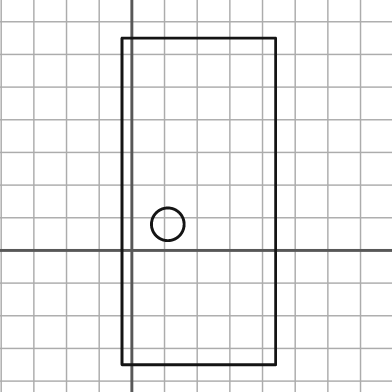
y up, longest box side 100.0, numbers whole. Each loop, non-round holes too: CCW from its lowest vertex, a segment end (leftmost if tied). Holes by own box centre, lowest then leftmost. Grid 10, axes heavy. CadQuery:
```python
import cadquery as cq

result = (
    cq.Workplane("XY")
    .moveTo(-3.0, -35.0)
    .lineTo(44.0, -35.0)
    .lineTo(44.0, 65.0)
    .lineTo(-3.0, 65.0)
    .close()
    .moveTo(11.0, 8.0)
    .circle(5.0)
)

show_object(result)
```